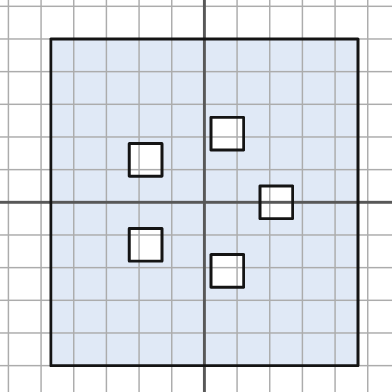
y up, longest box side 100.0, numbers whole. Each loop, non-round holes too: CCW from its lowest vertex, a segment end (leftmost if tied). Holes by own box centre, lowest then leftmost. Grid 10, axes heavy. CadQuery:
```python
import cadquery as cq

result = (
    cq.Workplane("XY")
    .moveTo(-47.0, -50.0)
    .lineTo(47.0, -50.0)
    .lineTo(47.0, 50.0)
    .lineTo(-47.0, 50.0)
    .close()
    .moveTo(2.0, -26.0)
    .lineTo(12.0, -26.0)
    .lineTo(12.0, -16.0)
    .lineTo(2.0, -16.0)
    .close()
    .moveTo(-23.0, -18.0)
    .lineTo(-13.0, -18.0)
    .lineTo(-13.0, -8.0)
    .lineTo(-23.0, -8.0)
    .close()
    .moveTo(17.0, -5.0)
    .lineTo(27.0, -5.0)
    .lineTo(27.0, 5.0)
    .lineTo(17.0, 5.0)
    .close()
    .moveTo(-23.0, 8.0)
    .lineTo(-13.0, 8.0)
    .lineTo(-13.0, 18.0)
    .lineTo(-23.0, 18.0)
    .close()
    .moveTo(2.0, 16.0)
    .lineTo(12.0, 16.0)
    .lineTo(12.0, 26.0)
    .lineTo(2.0, 26.0)
    .close()
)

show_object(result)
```